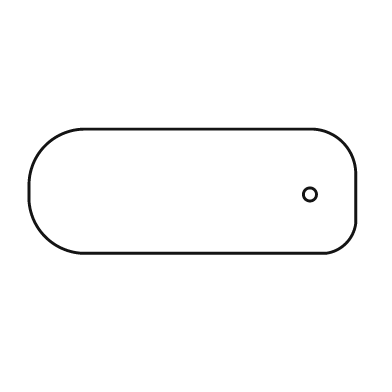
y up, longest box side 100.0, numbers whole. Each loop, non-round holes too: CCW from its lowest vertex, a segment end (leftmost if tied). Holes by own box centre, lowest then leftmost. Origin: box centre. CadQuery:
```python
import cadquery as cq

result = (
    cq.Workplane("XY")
    .moveTo(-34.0, -19.0)
    .lineTo(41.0, -19.0)
    .threePointArc((47.0, -16.0), (50.0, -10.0))
    .lineTo(50.0, 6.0)
    .threePointArc((46.0, 15.0), (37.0, 19.0))
    .lineTo(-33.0, 19.0)
    .threePointArc((-45.0, 14.0), (-50.0, 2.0))
    .lineTo(-50.0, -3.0)
    .threePointArc((-45.0, -14.0), (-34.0, -19.0))
    .close()
    .moveTo(36.0, -1.0)
    .circle(2.0)
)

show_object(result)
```